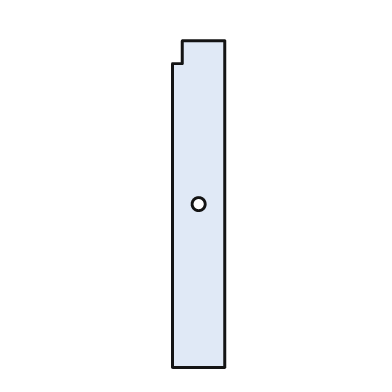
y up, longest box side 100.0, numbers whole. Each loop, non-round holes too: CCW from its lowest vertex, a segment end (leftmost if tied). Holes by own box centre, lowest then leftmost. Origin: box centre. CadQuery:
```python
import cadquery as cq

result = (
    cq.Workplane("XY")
    .moveTo(-8.0, -50.0)
    .lineTo(8.0, -50.0)
    .lineTo(8.0, 50.0)
    .lineTo(-5.0, 50.0)
    .lineTo(-5.0, 43.0)
    .lineTo(-8.0, 43.0)
    .close()
    .moveTo(0.0, 0.0)
    .circle(2.0)
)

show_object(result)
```